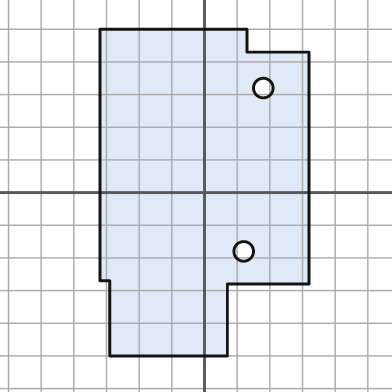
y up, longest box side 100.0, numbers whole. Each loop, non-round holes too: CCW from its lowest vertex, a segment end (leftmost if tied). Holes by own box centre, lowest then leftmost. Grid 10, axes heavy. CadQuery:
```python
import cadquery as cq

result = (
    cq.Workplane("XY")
    .moveTo(-29.0, -50.0)
    .lineTo(7.0, -50.0)
    .lineTo(7.0, -28.0)
    .lineTo(32.0, -28.0)
    .lineTo(32.0, 43.0)
    .lineTo(13.0, 43.0)
    .lineTo(13.0, 50.0)
    .lineTo(-32.0, 50.0)
    .lineTo(-32.0, -27.0)
    .lineTo(-29.0, -27.0)
    .close()
    .moveTo(12.0, -18.0)
    .circle(3.0)
    .moveTo(18.0, 32.0)
    .circle(3.0)
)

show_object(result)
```